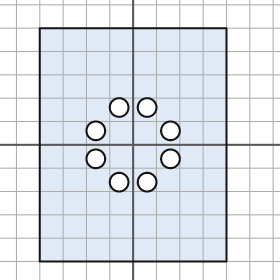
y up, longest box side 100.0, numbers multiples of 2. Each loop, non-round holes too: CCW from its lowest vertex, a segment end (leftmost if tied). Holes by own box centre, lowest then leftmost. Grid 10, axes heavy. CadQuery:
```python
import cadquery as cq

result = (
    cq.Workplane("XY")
    .moveTo(-40.0, -50.0)
    .lineTo(40.0, -50.0)
    .lineTo(40.0, 50.0)
    .lineTo(-40.0, 50.0)
    .close()
    .moveTo(-6.0, -16.0)
    .circle(4.0)
    .moveTo(6.0, -16.0)
    .circle(4.0)
    .moveTo(-16.0, -6.0)
    .circle(4.0)
    .moveTo(16.0, -6.0)
    .circle(4.0)
    .moveTo(-16.0, 6.0)
    .circle(4.0)
    .moveTo(16.0, 6.0)
    .circle(4.0)
    .moveTo(-6.0, 16.0)
    .circle(4.0)
    .moveTo(6.0, 16.0)
    .circle(4.0)
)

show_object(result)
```